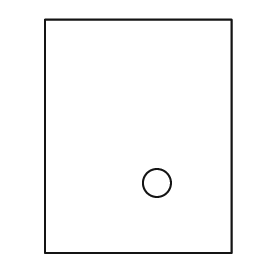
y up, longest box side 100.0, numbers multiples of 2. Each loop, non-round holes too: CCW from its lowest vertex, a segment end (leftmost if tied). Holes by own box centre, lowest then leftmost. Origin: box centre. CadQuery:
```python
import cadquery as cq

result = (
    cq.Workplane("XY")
    .moveTo(-40.0, -50.0)
    .lineTo(40.0, -50.0)
    .lineTo(40.0, 50.0)
    .lineTo(-40.0, 50.0)
    .close()
    .moveTo(8.0, -20.0)
    .circle(6.0)
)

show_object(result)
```